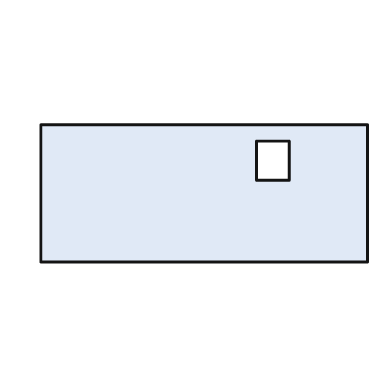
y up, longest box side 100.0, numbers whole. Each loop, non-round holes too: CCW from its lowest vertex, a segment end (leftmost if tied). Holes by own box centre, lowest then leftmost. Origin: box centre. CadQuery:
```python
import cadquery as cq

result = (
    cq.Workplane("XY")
    .moveTo(-50.0, -21.0)
    .lineTo(50.0, -21.0)
    .lineTo(50.0, 21.0)
    .lineTo(-50.0, 21.0)
    .close()
    .moveTo(16.0, 4.0)
    .lineTo(26.0, 4.0)
    .lineTo(26.0, 16.0)
    .lineTo(16.0, 16.0)
    .close()
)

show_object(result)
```